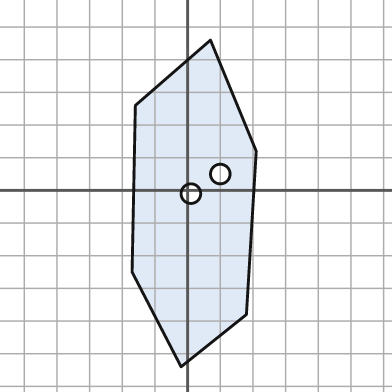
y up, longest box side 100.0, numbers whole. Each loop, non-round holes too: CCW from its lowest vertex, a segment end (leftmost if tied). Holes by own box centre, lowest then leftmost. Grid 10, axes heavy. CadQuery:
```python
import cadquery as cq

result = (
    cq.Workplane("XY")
    .moveTo(-2.0, -54.0)
    .lineTo(18.0, -38.0)
    .lineTo(21.0, 12.0)
    .lineTo(7.0, 46.0)
    .lineTo(-16.0, 26.0)
    .lineTo(-17.0, -25.0)
    .close()
    .moveTo(1.0, -1.0)
    .circle(3.0)
    .moveTo(10.0, 5.0)
    .circle(3.0)
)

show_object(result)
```